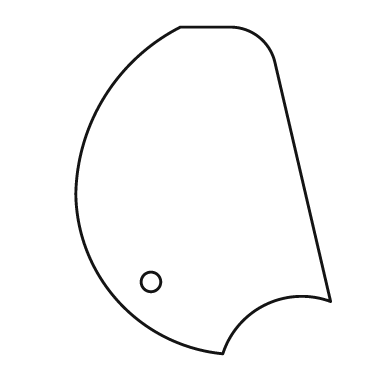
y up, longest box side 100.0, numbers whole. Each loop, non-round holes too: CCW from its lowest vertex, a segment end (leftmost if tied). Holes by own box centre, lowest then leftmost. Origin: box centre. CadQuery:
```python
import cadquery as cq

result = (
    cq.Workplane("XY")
    .moveTo(6.0, -50.0)
    .threePointArc((19.0, -35.0), (39.0, -34.0))
    .lineTo(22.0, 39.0)
    .threePointArc((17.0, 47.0), (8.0, 50.0))
    .lineTo(-7.0, 50.0)
    .threePointArc((-30.0, 29.0), (-39.0, -1.0))
    .threePointArc((-26.0, -34.0), (6.0, -50.0))
    .close()
    .moveTo(-16.0, -28.0)
    .circle(3.0)
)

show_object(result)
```